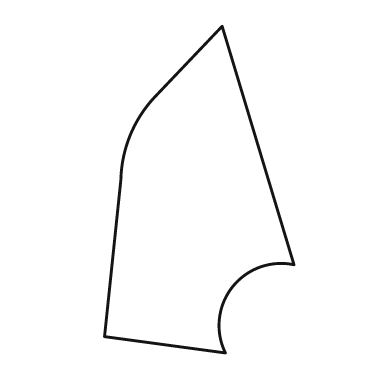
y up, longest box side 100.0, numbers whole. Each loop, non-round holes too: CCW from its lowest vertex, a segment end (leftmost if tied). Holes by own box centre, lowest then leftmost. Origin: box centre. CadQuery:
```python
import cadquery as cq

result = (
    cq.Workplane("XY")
    .moveTo(8.0, -50.0)
    .threePointArc((10.0, -30.0), (29.0, -23.0))
    .lineTo(7.0, 50.0)
    .lineTo(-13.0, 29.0)
    .threePointArc((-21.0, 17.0), (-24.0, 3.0))
    .lineTo(-29.0, -45.0)
    .close()
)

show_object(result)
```